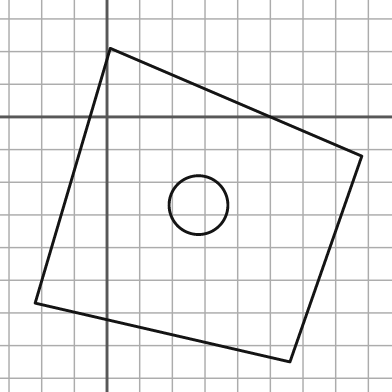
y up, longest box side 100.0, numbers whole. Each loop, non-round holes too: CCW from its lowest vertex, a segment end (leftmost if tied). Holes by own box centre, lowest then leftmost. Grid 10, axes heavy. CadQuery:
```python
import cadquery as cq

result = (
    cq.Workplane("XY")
    .moveTo(56.0, -75.0)
    .lineTo(78.0, -12.0)
    .lineTo(1.0, 21.0)
    .lineTo(-22.0, -57.0)
    .close()
    .moveTo(28.0, -27.0)
    .circle(9.0)
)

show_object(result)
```